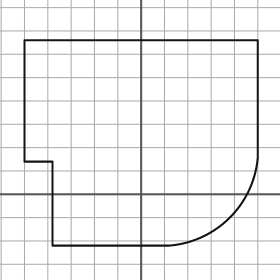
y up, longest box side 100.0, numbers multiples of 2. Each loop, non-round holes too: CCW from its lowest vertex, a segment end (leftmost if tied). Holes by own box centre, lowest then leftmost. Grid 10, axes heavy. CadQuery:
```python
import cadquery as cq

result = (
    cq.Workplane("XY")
    .moveTo(-38.0, -22.0)
    .lineTo(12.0, -22.0)
    .threePointArc((38.0, -10.0), (50.0, 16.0))
    .lineTo(50.0, 66.0)
    .lineTo(-50.0, 66.0)
    .lineTo(-50.0, 14.0)
    .lineTo(-38.0, 14.0)
    .close()
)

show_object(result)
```